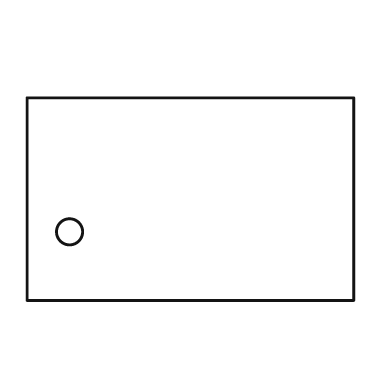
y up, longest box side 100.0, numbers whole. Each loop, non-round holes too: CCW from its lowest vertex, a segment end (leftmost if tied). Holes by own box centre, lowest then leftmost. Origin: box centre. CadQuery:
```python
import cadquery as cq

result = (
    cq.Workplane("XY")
    .moveTo(-50.0, -31.0)
    .lineTo(50.0, -31.0)
    .lineTo(50.0, 31.0)
    .lineTo(-50.0, 31.0)
    .close()
    .moveTo(-37.0, -10.0)
    .circle(4.0)
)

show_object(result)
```